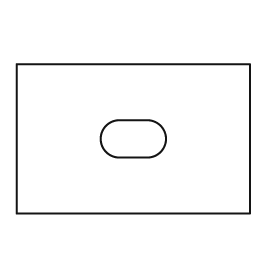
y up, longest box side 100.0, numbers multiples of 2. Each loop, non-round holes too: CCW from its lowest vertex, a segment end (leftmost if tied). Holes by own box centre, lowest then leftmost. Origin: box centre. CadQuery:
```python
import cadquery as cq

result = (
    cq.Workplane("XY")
    .moveTo(-50.0, -32.0)
    .lineTo(50.0, -32.0)
    .lineTo(50.0, 32.0)
    .lineTo(-50.0, 32.0)
    .close()
    .moveTo(-6.0, -8.0)
    .lineTo(6.0, -8.0)
    .threePointArc((14.0, 0.0), (6.0, 8.0))
    .lineTo(-6.0, 8.0)
    .threePointArc((-14.0, 0.0), (-6.0, -8.0))
    .close()
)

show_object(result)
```